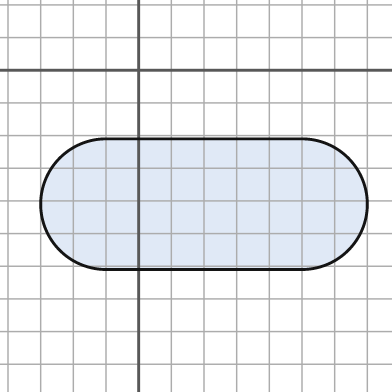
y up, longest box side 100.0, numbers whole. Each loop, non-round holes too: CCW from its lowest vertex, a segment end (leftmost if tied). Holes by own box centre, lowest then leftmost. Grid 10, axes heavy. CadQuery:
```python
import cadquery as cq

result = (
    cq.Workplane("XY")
    .moveTo(-10.0, -61.0)
    .lineTo(50.0, -61.0)
    .threePointArc((70.0, -41.0), (50.0, -21.0))
    .lineTo(-10.0, -21.0)
    .threePointArc((-30.0, -41.0), (-10.0, -61.0))
    .close()
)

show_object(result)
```